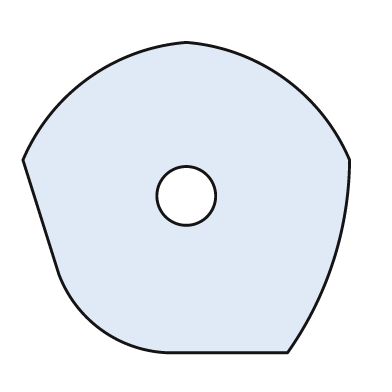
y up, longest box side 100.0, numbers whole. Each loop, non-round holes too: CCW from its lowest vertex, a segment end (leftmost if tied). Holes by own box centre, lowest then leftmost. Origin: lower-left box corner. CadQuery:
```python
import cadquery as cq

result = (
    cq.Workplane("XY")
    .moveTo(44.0, 0.0)
    .lineTo(81.0, 0.0)
    .threePointArc((95.0, 28.0), (100.0, 59.0))
    .threePointArc((80.0, 84.0), (50.0, 95.0))
    .threePointArc((20.0, 84.0), (0.0, 59.0))
    .lineTo(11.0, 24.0)
    .threePointArc((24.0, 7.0), (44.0, 0.0))
    .close()
    .moveTo(50.0, 48.0)
    .circle(9.0)
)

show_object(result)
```